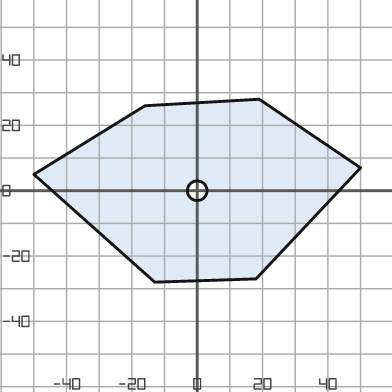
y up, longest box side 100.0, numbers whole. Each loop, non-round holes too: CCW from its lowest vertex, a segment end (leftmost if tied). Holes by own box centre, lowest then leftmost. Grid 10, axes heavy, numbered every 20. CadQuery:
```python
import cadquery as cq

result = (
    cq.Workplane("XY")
    .moveTo(-13.0, -28.0)
    .lineTo(18.0, -27.0)
    .lineTo(50.0, 7.0)
    .lineTo(19.0, 28.0)
    .lineTo(-16.0, 26.0)
    .lineTo(-50.0, 5.0)
    .close()
    .moveTo(0.0, 0.0)
    .circle(3.0)
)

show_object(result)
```